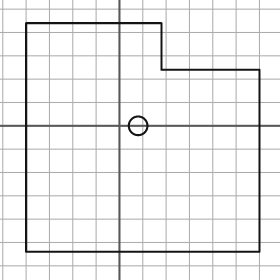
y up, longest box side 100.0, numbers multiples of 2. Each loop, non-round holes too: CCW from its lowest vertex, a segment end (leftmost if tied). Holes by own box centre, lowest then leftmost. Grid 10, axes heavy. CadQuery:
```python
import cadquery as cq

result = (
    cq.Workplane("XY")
    .moveTo(-40.0, -54.0)
    .lineTo(60.0, -54.0)
    .lineTo(60.0, 24.0)
    .lineTo(18.0, 24.0)
    .lineTo(18.0, 44.0)
    .lineTo(-40.0, 44.0)
    .close()
    .moveTo(8.0, 0.0)
    .circle(4.0)
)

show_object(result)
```